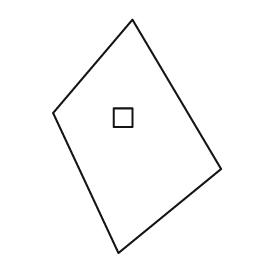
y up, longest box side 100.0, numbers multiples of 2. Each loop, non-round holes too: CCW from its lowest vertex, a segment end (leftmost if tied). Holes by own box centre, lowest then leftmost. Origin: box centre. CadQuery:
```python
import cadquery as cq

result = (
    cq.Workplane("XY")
    .moveTo(-8.0, -50.0)
    .lineTo(36.0, -14.0)
    .lineTo(-2.0, 50.0)
    .lineTo(-36.0, 10.0)
    .close()
    .moveTo(-10.0, 4.0)
    .lineTo(-2.0, 4.0)
    .lineTo(-2.0, 12.0)
    .lineTo(-10.0, 12.0)
    .close()
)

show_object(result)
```